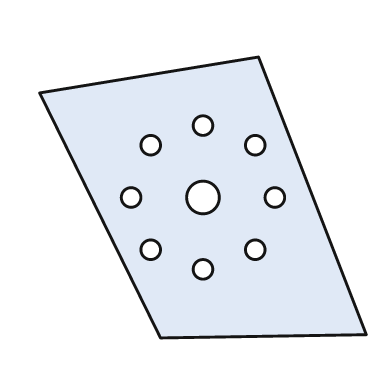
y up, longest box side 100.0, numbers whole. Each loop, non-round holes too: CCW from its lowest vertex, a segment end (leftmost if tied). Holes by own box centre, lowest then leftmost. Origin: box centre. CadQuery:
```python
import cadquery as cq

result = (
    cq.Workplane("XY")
    .moveTo(-13.0, -43.0)
    .lineTo(50.0, -42.0)
    .lineTo(17.0, 43.0)
    .lineTo(-50.0, 32.0)
    .close()
    .moveTo(0.0, -22.0)
    .circle(3.0)
    .moveTo(-16.0, -16.0)
    .circle(3.0)
    .moveTo(16.0, -16.0)
    .circle(3.0)
    .moveTo(-22.0, 0.0)
    .circle(3.0)
    .moveTo(0.0, 0.0)
    .circle(5.0)
    .moveTo(22.0, 0.0)
    .circle(3.0)
    .moveTo(-16.0, 16.0)
    .circle(3.0)
    .moveTo(16.0, 16.0)
    .circle(3.0)
    .moveTo(0.0, 22.0)
    .circle(3.0)
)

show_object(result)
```